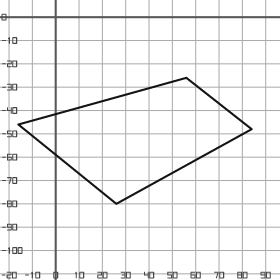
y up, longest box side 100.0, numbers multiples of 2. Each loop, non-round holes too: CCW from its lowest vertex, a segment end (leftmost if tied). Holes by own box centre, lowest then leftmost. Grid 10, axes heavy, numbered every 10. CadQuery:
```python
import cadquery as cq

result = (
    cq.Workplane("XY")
    .moveTo(26.0, -80.0)
    .lineTo(84.0, -48.0)
    .lineTo(56.0, -26.0)
    .lineTo(-16.0, -46.0)
    .close()
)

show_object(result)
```